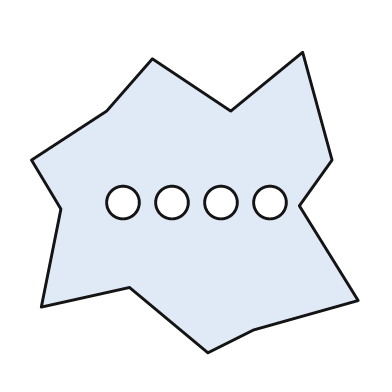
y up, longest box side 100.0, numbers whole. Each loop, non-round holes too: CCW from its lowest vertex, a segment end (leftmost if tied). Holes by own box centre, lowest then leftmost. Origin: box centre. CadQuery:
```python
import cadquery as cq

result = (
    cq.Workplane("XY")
    .moveTo(4.0, -46.0)
    .lineTo(18.0, -39.0)
    .lineTo(50.0, -30.0)
    .lineTo(32.0, -1.0)
    .lineTo(42.0, 13.0)
    .lineTo(33.0, 46.0)
    .lineTo(11.0, 28.0)
    .lineTo(-13.0, 44.0)
    .lineTo(-27.0, 28.0)
    .lineTo(-50.0, 13.0)
    .lineTo(-41.0, -2.0)
    .lineTo(-47.0, -32.0)
    .lineTo(-20.0, -26.0)
    .close()
    .moveTo(-22.0, 0.0)
    .circle(5.0)
    .moveTo(-7.0, 0.0)
    .circle(5.0)
    .moveTo(8.0, 0.0)
    .circle(5.0)
    .moveTo(23.0, 0.0)
    .circle(5.0)
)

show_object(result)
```